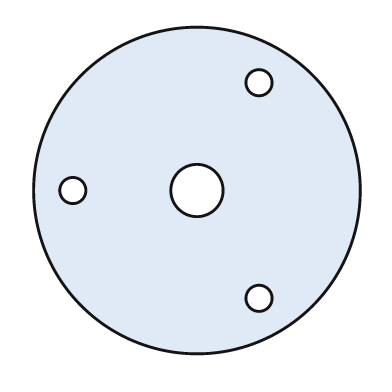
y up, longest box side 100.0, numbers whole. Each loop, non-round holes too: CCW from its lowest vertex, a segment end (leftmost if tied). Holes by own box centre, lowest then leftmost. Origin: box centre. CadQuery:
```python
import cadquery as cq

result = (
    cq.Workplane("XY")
    .moveTo(0.0, 0.0)
    .circle(50.0)
    .moveTo(19.0, -33.0)
    .circle(4.0)
    .moveTo(-38.0, 0.0)
    .circle(4.0)
    .moveTo(0.0, 0.0)
    .circle(8.0)
    .moveTo(19.0, 33.0)
    .circle(4.0)
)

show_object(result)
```